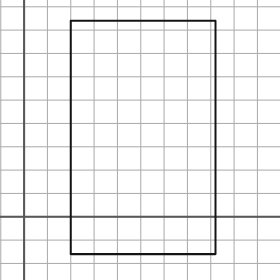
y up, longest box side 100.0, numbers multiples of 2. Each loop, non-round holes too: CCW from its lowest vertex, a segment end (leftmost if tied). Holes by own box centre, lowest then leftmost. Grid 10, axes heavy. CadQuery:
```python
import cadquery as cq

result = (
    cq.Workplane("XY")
    .moveTo(20.0, -16.0)
    .lineTo(82.0, -16.0)
    .lineTo(82.0, 84.0)
    .lineTo(20.0, 84.0)
    .close()
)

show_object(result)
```